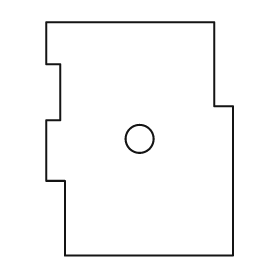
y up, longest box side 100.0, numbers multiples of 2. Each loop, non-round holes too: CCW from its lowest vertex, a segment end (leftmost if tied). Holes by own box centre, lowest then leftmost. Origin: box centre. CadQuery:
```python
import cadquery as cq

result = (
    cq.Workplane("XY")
    .moveTo(-32.0, -50.0)
    .lineTo(40.0, -50.0)
    .lineTo(40.0, 14.0)
    .lineTo(32.0, 14.0)
    .lineTo(32.0, 50.0)
    .lineTo(-40.0, 50.0)
    .lineTo(-40.0, 32.0)
    .lineTo(-34.0, 32.0)
    .lineTo(-34.0, 8.0)
    .lineTo(-40.0, 8.0)
    .lineTo(-40.0, -18.0)
    .lineTo(-32.0, -18.0)
    .close()
    .moveTo(0.0, 0.0)
    .circle(6.0)
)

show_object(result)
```